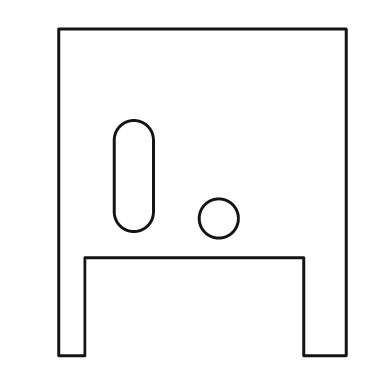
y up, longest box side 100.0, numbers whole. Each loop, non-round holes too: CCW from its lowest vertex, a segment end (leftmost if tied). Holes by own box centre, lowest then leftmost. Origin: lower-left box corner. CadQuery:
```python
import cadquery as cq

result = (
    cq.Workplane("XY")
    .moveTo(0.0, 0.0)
    .lineTo(8.0, 0.0)
    .lineTo(8.0, 30.0)
    .lineTo(75.0, 30.0)
    .lineTo(75.0, 0.0)
    .lineTo(88.0, 0.0)
    .lineTo(88.0, 100.0)
    .lineTo(0.0, 100.0)
    .close()
    .moveTo(49.0, 42.0)
    .circle(6.0)
    .moveTo(17.0, 44.0)
    .threePointArc((23.0, 38.0), (29.0, 44.0))
    .lineTo(29.0, 66.0)
    .threePointArc((23.0, 72.0), (17.0, 66.0))
    .close()
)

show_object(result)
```